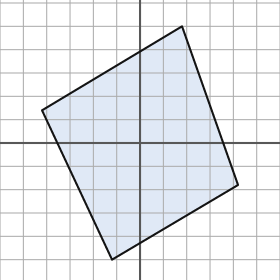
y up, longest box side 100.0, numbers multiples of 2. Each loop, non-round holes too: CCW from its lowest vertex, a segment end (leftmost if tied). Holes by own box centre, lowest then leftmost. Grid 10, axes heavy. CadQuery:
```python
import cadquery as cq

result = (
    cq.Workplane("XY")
    .moveTo(-12.0, -50.0)
    .lineTo(42.0, -18.0)
    .lineTo(18.0, 50.0)
    .lineTo(-42.0, 14.0)
    .close()
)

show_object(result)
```